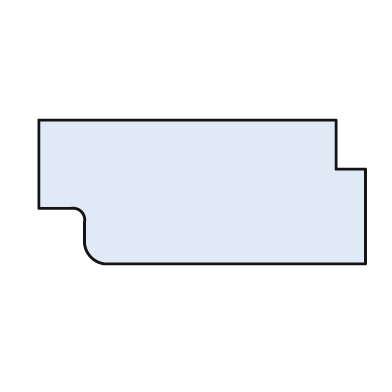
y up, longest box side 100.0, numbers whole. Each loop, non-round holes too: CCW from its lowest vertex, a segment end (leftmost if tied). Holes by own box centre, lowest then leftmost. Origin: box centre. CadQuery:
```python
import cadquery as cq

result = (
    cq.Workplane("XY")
    .moveTo(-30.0, -22.0)
    .lineTo(50.0, -22.0)
    .lineTo(50.0, 7.0)
    .lineTo(41.0, 7.0)
    .lineTo(41.0, 22.0)
    .lineTo(-50.0, 22.0)
    .lineTo(-50.0, -5.0)
    .lineTo(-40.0, -5.0)
    .threePointArc((-37.0, -6.0), (-36.0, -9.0))
    .lineTo(-36.0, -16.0)
    .threePointArc((-34.0, -20.0), (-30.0, -22.0))
    .close()
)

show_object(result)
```